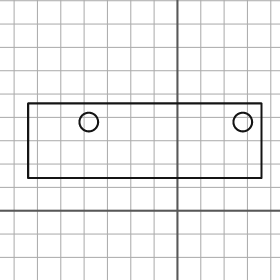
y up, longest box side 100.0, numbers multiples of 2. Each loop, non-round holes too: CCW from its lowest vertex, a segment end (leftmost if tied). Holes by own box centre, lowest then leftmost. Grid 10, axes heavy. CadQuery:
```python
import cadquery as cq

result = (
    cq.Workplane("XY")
    .moveTo(-64.0, 14.0)
    .lineTo(36.0, 14.0)
    .lineTo(36.0, 46.0)
    .lineTo(-64.0, 46.0)
    .close()
    .moveTo(-38.0, 38.0)
    .circle(4.0)
    .moveTo(28.0, 38.0)
    .circle(4.0)
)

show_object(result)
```